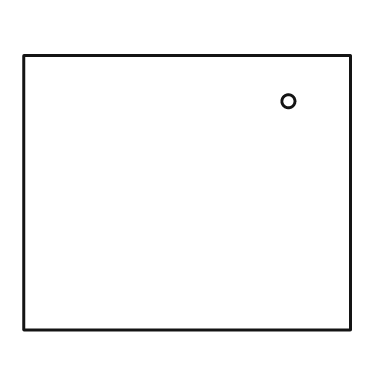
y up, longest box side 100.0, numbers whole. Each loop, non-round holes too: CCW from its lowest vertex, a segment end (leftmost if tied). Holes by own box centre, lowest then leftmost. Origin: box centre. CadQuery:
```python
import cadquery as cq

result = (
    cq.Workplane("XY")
    .moveTo(-50.0, -42.0)
    .lineTo(50.0, -42.0)
    .lineTo(50.0, 42.0)
    .lineTo(-50.0, 42.0)
    .close()
    .moveTo(31.0, 28.0)
    .circle(2.0)
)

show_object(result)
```